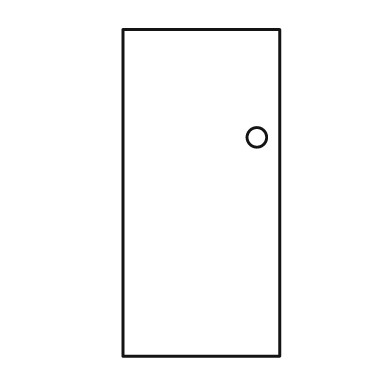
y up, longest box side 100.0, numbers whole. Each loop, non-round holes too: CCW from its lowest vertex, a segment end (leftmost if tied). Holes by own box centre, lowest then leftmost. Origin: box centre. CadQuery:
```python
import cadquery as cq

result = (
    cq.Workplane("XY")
    .moveTo(-24.0, -50.0)
    .lineTo(24.0, -50.0)
    .lineTo(24.0, 50.0)
    .lineTo(-24.0, 50.0)
    .close()
    .moveTo(17.0, 17.0)
    .circle(3.0)
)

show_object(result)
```